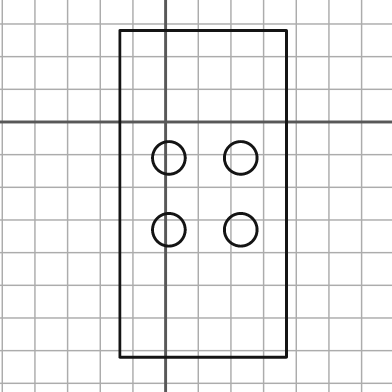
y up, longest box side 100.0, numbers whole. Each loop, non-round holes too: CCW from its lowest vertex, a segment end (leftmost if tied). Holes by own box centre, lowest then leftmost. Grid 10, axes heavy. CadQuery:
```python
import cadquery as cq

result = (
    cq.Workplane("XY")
    .moveTo(-14.0, -72.0)
    .lineTo(37.0, -72.0)
    .lineTo(37.0, 28.0)
    .lineTo(-14.0, 28.0)
    .close()
    .moveTo(1.0, -33.0)
    .circle(5.0)
    .moveTo(23.0, -33.0)
    .circle(5.0)
    .moveTo(1.0, -11.0)
    .circle(5.0)
    .moveTo(23.0, -11.0)
    .circle(5.0)
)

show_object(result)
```